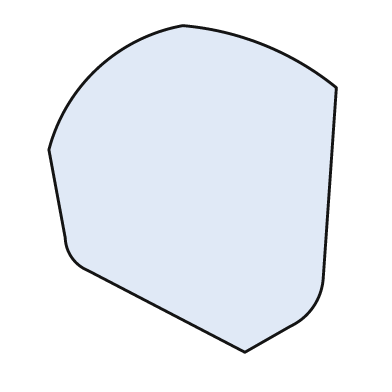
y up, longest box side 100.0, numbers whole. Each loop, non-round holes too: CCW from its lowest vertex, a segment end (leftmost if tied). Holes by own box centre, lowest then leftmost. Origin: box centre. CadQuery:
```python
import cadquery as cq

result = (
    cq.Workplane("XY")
    .moveTo(16.0, -50.0)
    .lineTo(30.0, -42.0)
    .threePointArc((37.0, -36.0), (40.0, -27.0))
    .lineTo(44.0, 31.0)
    .threePointArc((22.0, 44.0), (-3.0, 50.0))
    .threePointArc((-29.0, 37.0), (-44.0, 12.0))
    .lineTo(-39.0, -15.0)
    .threePointArc((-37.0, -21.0), (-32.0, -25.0))
    .close()
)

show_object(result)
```